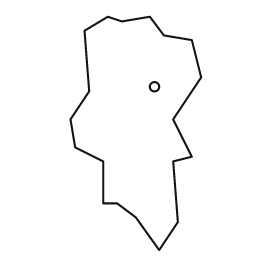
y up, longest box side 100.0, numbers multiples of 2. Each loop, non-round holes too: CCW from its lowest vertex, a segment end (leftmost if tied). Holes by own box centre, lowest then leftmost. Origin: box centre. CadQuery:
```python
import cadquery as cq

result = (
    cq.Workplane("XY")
    .moveTo(10.0, -50.0)
    .lineTo(18.0, -38.0)
    .lineTo(16.0, -12.0)
    .lineTo(24.0, -10.0)
    .lineTo(16.0, 6.0)
    .lineTo(28.0, 24.0)
    .lineTo(24.0, 40.0)
    .lineTo(12.0, 42.0)
    .lineTo(6.0, 50.0)
    .lineTo(-6.0, 48.0)
    .lineTo(-12.0, 50.0)
    .lineTo(-22.0, 44.0)
    .lineTo(-20.0, 18.0)
    .lineTo(-28.0, 6.0)
    .lineTo(-26.0, -6.0)
    .lineTo(-14.0, -12.0)
    .lineTo(-14.0, -30.0)
    .lineTo(-8.0, -30.0)
    .lineTo(0.0, -36.0)
    .close()
    .moveTo(8.0, 20.0)
    .circle(2.0)
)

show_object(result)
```